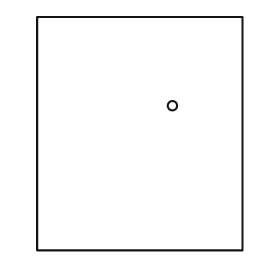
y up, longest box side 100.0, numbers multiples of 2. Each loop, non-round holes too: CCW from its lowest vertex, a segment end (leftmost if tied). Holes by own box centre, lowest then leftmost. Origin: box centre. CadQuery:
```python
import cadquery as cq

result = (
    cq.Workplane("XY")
    .moveTo(-44.0, -50.0)
    .lineTo(44.0, -50.0)
    .lineTo(44.0, 50.0)
    .lineTo(-44.0, 50.0)
    .close()
    .moveTo(14.0, 12.0)
    .circle(2.0)
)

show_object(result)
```